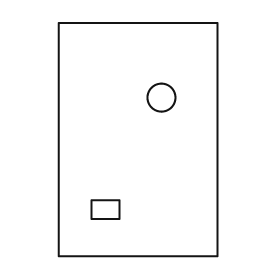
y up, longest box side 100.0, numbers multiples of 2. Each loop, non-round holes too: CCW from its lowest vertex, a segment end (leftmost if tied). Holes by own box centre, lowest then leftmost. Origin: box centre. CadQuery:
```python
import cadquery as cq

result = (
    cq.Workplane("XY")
    .moveTo(-34.0, -50.0)
    .lineTo(34.0, -50.0)
    .lineTo(34.0, 50.0)
    .lineTo(-34.0, 50.0)
    .close()
    .moveTo(-20.0, -34.0)
    .lineTo(-8.0, -34.0)
    .lineTo(-8.0, -26.0)
    .lineTo(-20.0, -26.0)
    .close()
    .moveTo(10.0, 18.0)
    .circle(6.0)
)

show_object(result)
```